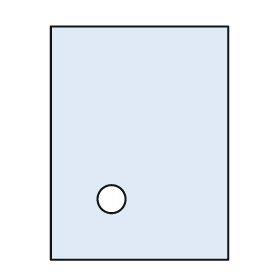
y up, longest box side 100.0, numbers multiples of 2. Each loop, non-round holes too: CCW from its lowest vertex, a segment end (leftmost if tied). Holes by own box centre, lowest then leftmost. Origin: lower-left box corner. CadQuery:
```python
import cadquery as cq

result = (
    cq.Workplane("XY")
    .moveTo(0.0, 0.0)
    .lineTo(76.0, 0.0)
    .lineTo(76.0, 100.0)
    .lineTo(0.0, 100.0)
    .close()
    .moveTo(26.0, 26.0)
    .circle(6.0)
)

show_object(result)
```